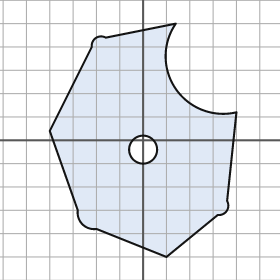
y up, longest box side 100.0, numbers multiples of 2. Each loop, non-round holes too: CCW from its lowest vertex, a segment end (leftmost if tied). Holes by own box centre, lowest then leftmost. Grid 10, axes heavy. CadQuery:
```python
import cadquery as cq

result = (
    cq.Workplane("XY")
    .moveTo(10.0, -50.0)
    .lineTo(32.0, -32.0)
    .threePointArc((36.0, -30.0), (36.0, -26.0))
    .lineTo(40.0, 12.0)
    .threePointArc((14.0, 22.0), (14.0, 50.0))
    .lineTo(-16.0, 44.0)
    .threePointArc((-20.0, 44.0), (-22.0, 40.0))
    .lineTo(-40.0, 4.0)
    .lineTo(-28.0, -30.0)
    .threePointArc((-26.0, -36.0), (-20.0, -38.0))
    .close()
    .moveTo(0.0, -4.0)
    .circle(6.0)
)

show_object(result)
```